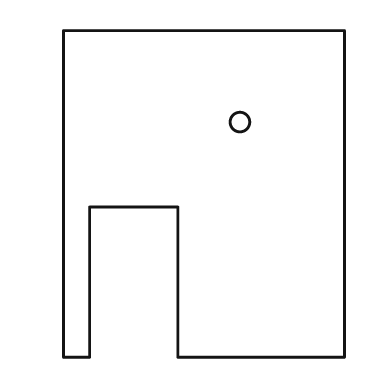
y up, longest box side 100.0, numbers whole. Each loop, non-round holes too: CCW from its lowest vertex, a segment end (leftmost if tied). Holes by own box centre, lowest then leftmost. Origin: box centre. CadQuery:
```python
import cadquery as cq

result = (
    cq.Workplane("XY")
    .moveTo(-43.0, -50.0)
    .lineTo(-35.0, -50.0)
    .lineTo(-35.0, -4.0)
    .lineTo(-8.0, -4.0)
    .lineTo(-8.0, -50.0)
    .lineTo(43.0, -50.0)
    .lineTo(43.0, 50.0)
    .lineTo(-43.0, 50.0)
    .close()
    .moveTo(11.0, 22.0)
    .circle(3.0)
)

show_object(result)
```